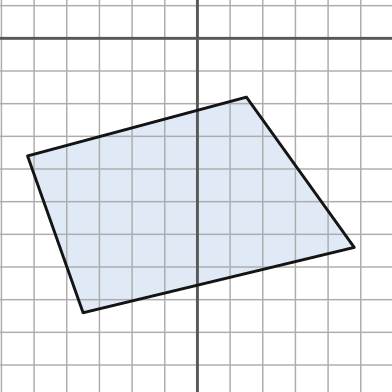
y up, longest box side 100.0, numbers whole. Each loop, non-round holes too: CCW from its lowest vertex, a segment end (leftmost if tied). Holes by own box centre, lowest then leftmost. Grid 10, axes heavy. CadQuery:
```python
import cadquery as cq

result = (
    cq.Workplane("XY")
    .moveTo(-35.0, -84.0)
    .lineTo(48.0, -64.0)
    .lineTo(15.0, -18.0)
    .lineTo(-52.0, -36.0)
    .close()
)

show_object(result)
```